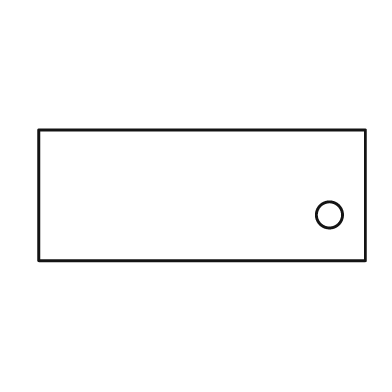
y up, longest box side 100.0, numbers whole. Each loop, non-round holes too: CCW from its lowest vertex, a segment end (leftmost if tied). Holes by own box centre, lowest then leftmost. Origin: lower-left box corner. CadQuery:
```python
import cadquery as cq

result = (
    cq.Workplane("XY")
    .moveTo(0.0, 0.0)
    .lineTo(100.0, 0.0)
    .lineTo(100.0, 40.0)
    .lineTo(0.0, 40.0)
    .close()
    .moveTo(89.0, 14.0)
    .circle(4.0)
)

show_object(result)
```